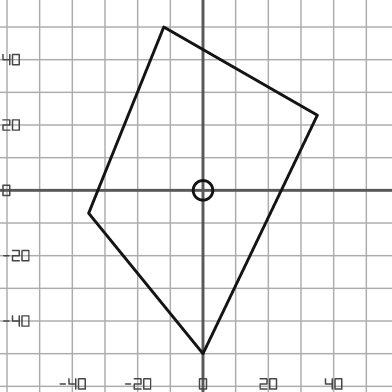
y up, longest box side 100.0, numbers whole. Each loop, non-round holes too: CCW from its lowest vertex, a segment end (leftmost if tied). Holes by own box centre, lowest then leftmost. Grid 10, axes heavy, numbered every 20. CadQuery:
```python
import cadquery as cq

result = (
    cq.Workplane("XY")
    .moveTo(0.0, -50.0)
    .lineTo(35.0, 23.0)
    .lineTo(-12.0, 50.0)
    .lineTo(-35.0, -7.0)
    .close()
    .moveTo(0.0, 0.0)
    .circle(3.0)
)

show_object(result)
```